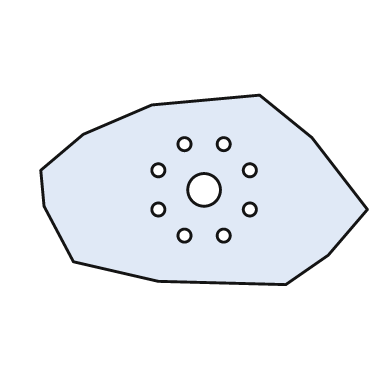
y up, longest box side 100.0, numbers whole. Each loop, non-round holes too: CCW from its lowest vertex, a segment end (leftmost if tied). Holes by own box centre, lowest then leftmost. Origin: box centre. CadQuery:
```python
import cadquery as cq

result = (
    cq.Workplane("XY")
    .moveTo(25.0, -29.0)
    .lineTo(38.0, -20.0)
    .lineTo(50.0, -6.0)
    .lineTo(33.0, 16.0)
    .lineTo(17.0, 29.0)
    .lineTo(-16.0, 26.0)
    .lineTo(-37.0, 17.0)
    .lineTo(-50.0, 6.0)
    .lineTo(-49.0, -5.0)
    .lineTo(-40.0, -22.0)
    .lineTo(-14.0, -28.0)
    .close()
    .moveTo(-6.0, -14.0)
    .circle(2.0)
    .moveTo(6.0, -14.0)
    .circle(2.0)
    .moveTo(-14.0, -6.0)
    .circle(2.0)
    .moveTo(14.0, -6.0)
    .circle(2.0)
    .moveTo(0.0, 0.0)
    .circle(5.0)
    .moveTo(-14.0, 6.0)
    .circle(2.0)
    .moveTo(14.0, 6.0)
    .circle(2.0)
    .moveTo(-6.0, 14.0)
    .circle(2.0)
    .moveTo(6.0, 14.0)
    .circle(2.0)
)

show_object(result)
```